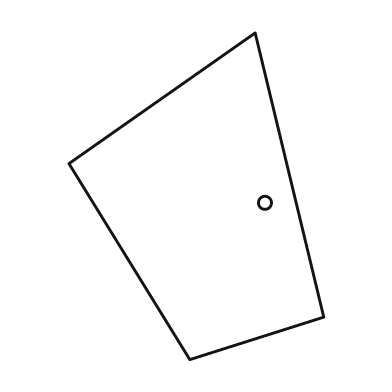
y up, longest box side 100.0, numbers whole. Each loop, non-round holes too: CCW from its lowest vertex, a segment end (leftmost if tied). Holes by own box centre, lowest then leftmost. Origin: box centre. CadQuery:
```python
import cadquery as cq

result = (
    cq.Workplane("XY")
    .moveTo(-2.0, -50.0)
    .lineTo(39.0, -37.0)
    .lineTo(18.0, 50.0)
    .lineTo(-39.0, 10.0)
    .close()
    .moveTo(21.0, -2.0)
    .circle(2.0)
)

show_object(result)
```